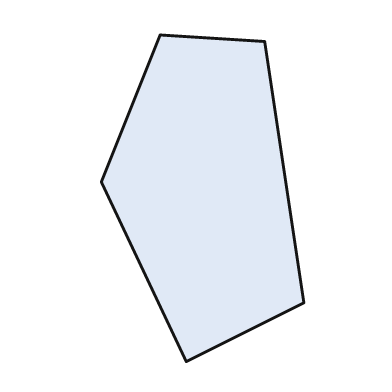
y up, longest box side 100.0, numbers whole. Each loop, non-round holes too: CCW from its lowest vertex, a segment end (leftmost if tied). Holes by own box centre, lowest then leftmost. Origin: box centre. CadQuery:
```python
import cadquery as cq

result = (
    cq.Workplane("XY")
    .moveTo(-5.0, -50.0)
    .lineTo(31.0, -32.0)
    .lineTo(19.0, 48.0)
    .lineTo(-13.0, 50.0)
    .lineTo(-31.0, 5.0)
    .close()
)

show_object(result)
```